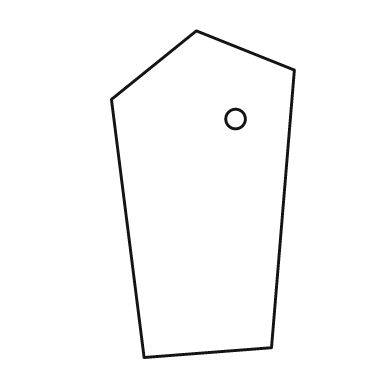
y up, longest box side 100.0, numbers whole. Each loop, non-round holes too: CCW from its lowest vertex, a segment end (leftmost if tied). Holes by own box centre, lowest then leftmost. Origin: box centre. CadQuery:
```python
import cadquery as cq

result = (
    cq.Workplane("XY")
    .moveTo(-18.0, -50.0)
    .lineTo(21.0, -47.0)
    .lineTo(28.0, 38.0)
    .lineTo(-2.0, 50.0)
    .lineTo(-28.0, 29.0)
    .close()
    .moveTo(10.0, 23.0)
    .circle(3.0)
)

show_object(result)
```